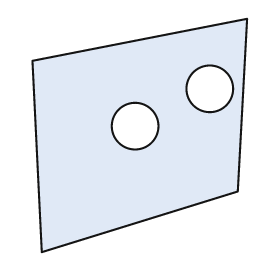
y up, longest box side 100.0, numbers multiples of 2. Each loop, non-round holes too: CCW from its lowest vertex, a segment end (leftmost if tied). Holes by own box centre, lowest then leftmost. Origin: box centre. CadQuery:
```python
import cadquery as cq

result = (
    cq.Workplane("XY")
    .moveTo(-42.0, -50.0)
    .lineTo(42.0, -24.0)
    .lineTo(46.0, 50.0)
    .lineTo(-46.0, 32.0)
    .close()
    .moveTo(-2.0, 4.0)
    .circle(10.0)
    .moveTo(30.0, 20.0)
    .circle(10.0)
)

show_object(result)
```